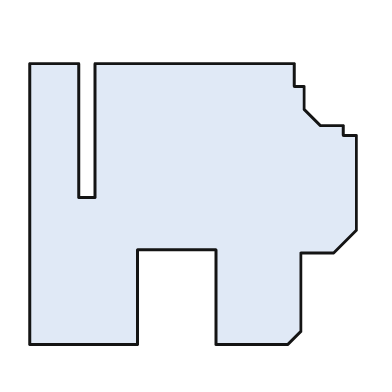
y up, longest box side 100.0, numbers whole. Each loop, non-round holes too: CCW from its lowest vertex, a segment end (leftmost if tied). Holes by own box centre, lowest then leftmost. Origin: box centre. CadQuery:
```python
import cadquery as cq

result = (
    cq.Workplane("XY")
    .moveTo(-50.0, -43.0)
    .lineTo(-17.0, -43.0)
    .lineTo(-17.0, -14.0)
    .lineTo(7.0, -14.0)
    .lineTo(7.0, -43.0)
    .lineTo(29.0, -43.0)
    .lineTo(33.0, -39.0)
    .lineTo(33.0, -15.0)
    .lineTo(43.0, -15.0)
    .lineTo(50.0, -8.0)
    .lineTo(50.0, 21.0)
    .lineTo(46.0, 21.0)
    .lineTo(46.0, 24.0)
    .lineTo(39.0, 24.0)
    .lineTo(34.0, 29.0)
    .lineTo(34.0, 36.0)
    .lineTo(31.0, 36.0)
    .lineTo(31.0, 43.0)
    .lineTo(-30.0, 43.0)
    .lineTo(-30.0, 2.0)
    .lineTo(-35.0, 2.0)
    .lineTo(-35.0, 43.0)
    .lineTo(-50.0, 43.0)
    .close()
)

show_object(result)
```